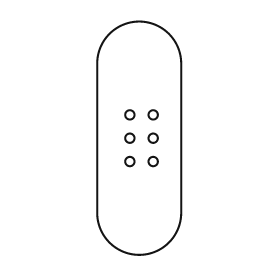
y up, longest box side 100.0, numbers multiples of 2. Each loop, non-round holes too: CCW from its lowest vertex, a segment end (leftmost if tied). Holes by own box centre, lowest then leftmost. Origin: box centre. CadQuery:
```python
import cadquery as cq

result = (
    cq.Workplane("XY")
    .moveTo(-18.0, -32.0)
    .threePointArc((0.0, -50.0), (18.0, -32.0))
    .lineTo(18.0, 32.0)
    .threePointArc((0.0, 50.0), (-18.0, 32.0))
    .close()
    .moveTo(-4.0, -10.0)
    .circle(2.0)
    .moveTo(6.0, -10.0)
    .circle(2.0)
    .moveTo(-4.0, 0.0)
    .circle(2.0)
    .moveTo(6.0, 0.0)
    .circle(2.0)
    .moveTo(-4.0, 10.0)
    .circle(2.0)
    .moveTo(6.0, 10.0)
    .circle(2.0)
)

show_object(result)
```